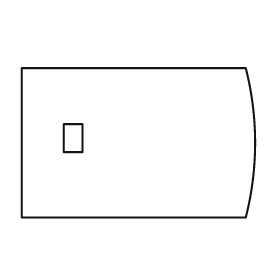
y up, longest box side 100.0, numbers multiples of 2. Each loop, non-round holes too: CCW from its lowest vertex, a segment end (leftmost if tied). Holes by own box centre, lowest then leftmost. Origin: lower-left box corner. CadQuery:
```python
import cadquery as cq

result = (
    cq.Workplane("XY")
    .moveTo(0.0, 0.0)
    .lineTo(96.0, 0.0)
    .threePointArc((100.0, 32.0), (96.0, 64.0))
    .lineTo(0.0, 64.0)
    .close()
    .moveTo(18.0, 28.0)
    .lineTo(26.0, 28.0)
    .lineTo(26.0, 40.0)
    .lineTo(18.0, 40.0)
    .close()
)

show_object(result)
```